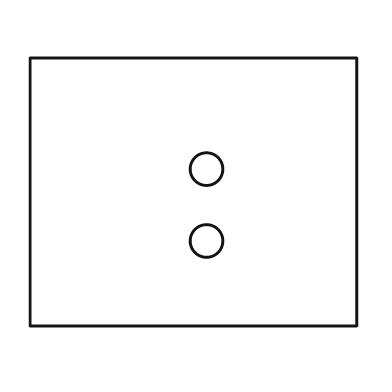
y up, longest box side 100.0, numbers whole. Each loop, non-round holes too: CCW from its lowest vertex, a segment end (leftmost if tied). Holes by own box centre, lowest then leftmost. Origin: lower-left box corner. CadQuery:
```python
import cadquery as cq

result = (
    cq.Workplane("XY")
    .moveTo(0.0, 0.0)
    .lineTo(100.0, 0.0)
    .lineTo(100.0, 82.0)
    .lineTo(0.0, 82.0)
    .close()
    .moveTo(54.0, 26.0)
    .circle(5.0)
    .moveTo(54.0, 48.0)
    .circle(5.0)
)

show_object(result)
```